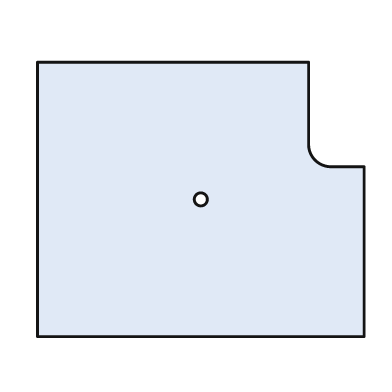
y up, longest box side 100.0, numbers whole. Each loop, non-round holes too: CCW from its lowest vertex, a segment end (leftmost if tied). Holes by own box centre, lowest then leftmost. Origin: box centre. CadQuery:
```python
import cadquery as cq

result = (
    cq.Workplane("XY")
    .moveTo(-50.0, -42.0)
    .lineTo(50.0, -42.0)
    .lineTo(50.0, 10.0)
    .lineTo(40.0, 10.0)
    .threePointArc((35.0, 12.0), (33.0, 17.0))
    .lineTo(33.0, 42.0)
    .lineTo(-50.0, 42.0)
    .close()
    .moveTo(0.0, 0.0)
    .circle(2.0)
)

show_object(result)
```